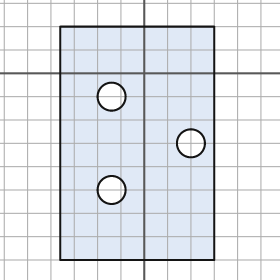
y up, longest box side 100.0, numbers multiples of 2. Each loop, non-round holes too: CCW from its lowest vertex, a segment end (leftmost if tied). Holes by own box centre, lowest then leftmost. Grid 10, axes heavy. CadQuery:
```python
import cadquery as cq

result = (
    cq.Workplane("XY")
    .moveTo(-36.0, -80.0)
    .lineTo(30.0, -80.0)
    .lineTo(30.0, 20.0)
    .lineTo(-36.0, 20.0)
    .close()
    .moveTo(-14.0, -50.0)
    .circle(6.0)
    .moveTo(20.0, -30.0)
    .circle(6.0)
    .moveTo(-14.0, -10.0)
    .circle(6.0)
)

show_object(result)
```